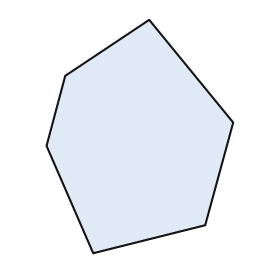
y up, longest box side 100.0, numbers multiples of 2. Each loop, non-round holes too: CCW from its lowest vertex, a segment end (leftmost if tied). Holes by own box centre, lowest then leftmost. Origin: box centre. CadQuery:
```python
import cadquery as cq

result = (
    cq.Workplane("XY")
    .moveTo(-20.0, -50.0)
    .lineTo(28.0, -38.0)
    .lineTo(40.0, 6.0)
    .lineTo(4.0, 50.0)
    .lineTo(-32.0, 26.0)
    .lineTo(-40.0, -4.0)
    .close()
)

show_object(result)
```